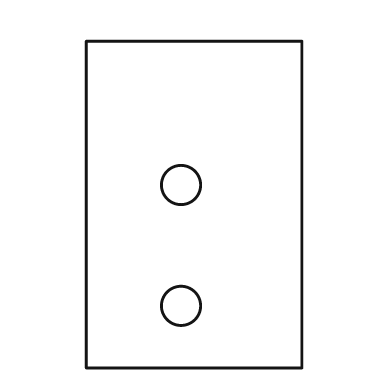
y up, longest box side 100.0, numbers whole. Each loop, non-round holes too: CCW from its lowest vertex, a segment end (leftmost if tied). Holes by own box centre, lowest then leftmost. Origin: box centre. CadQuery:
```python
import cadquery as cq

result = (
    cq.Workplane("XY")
    .moveTo(-33.0, -50.0)
    .lineTo(33.0, -50.0)
    .lineTo(33.0, 50.0)
    .lineTo(-33.0, 50.0)
    .close()
    .moveTo(-4.0, -31.0)
    .circle(6.0)
    .moveTo(-4.0, 6.0)
    .circle(6.0)
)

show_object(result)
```